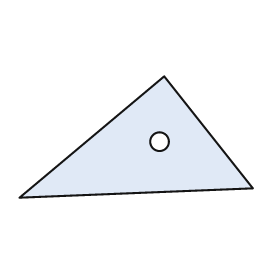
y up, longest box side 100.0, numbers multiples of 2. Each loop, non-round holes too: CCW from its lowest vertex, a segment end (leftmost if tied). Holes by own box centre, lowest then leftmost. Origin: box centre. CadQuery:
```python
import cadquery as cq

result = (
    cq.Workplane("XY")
    .moveTo(-50.0, -26.0)
    .lineTo(50.0, -22.0)
    .lineTo(12.0, 26.0)
    .close()
    .moveTo(10.0, -2.0)
    .circle(4.0)
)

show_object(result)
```